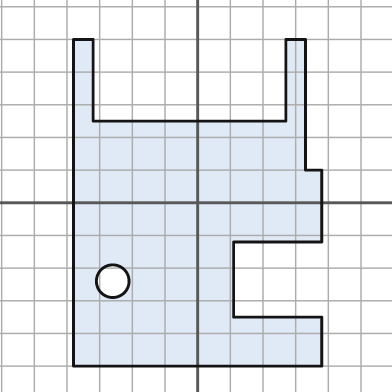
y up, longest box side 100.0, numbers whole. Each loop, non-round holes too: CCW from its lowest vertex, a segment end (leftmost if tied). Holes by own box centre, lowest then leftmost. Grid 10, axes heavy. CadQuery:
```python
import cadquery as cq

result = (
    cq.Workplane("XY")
    .moveTo(-38.0, -50.0)
    .lineTo(38.0, -50.0)
    .lineTo(38.0, -35.0)
    .lineTo(11.0, -35.0)
    .lineTo(11.0, -12.0)
    .lineTo(38.0, -12.0)
    .lineTo(38.0, 10.0)
    .lineTo(33.0, 10.0)
    .lineTo(33.0, 50.0)
    .lineTo(27.0, 50.0)
    .lineTo(27.0, 25.0)
    .lineTo(-32.0, 25.0)
    .lineTo(-32.0, 50.0)
    .lineTo(-38.0, 50.0)
    .close()
    .moveTo(-26.0, -24.0)
    .circle(5.0)
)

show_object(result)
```